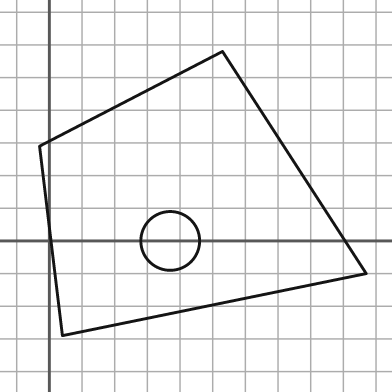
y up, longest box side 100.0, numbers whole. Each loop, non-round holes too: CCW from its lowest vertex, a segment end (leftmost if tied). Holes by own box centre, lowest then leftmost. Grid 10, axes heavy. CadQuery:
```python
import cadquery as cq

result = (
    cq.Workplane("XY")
    .moveTo(4.0, -29.0)
    .lineTo(97.0, -10.0)
    .lineTo(53.0, 58.0)
    .lineTo(-3.0, 29.0)
    .close()
    .moveTo(37.0, 0.0)
    .circle(9.0)
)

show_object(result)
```